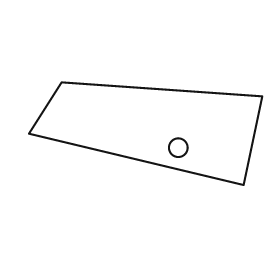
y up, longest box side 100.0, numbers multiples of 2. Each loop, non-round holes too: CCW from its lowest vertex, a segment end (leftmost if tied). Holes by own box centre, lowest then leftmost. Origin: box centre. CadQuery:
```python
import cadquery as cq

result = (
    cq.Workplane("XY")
    .moveTo(42.0, -22.0)
    .lineTo(50.0, 16.0)
    .lineTo(-36.0, 22.0)
    .lineTo(-50.0, 0.0)
    .close()
    .moveTo(14.0, -6.0)
    .circle(4.0)
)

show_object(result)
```